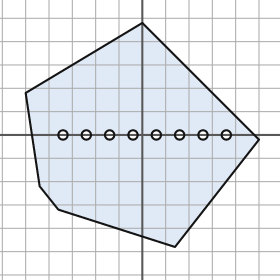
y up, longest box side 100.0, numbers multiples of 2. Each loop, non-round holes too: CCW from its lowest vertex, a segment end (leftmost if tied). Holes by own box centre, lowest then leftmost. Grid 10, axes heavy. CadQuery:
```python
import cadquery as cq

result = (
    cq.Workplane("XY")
    .moveTo(14.0, -48.0)
    .lineTo(50.0, -2.0)
    .lineTo(0.0, 48.0)
    .lineTo(-50.0, 18.0)
    .lineTo(-44.0, -22.0)
    .lineTo(-36.0, -32.0)
    .close()
    .moveTo(-34.0, 0.0)
    .circle(2.0)
    .moveTo(-24.0, 0.0)
    .circle(2.0)
    .moveTo(-14.0, 0.0)
    .circle(2.0)
    .moveTo(-4.0, 0.0)
    .circle(2.0)
    .moveTo(6.0, 0.0)
    .circle(2.0)
    .moveTo(16.0, 0.0)
    .circle(2.0)
    .moveTo(26.0, 0.0)
    .circle(2.0)
    .moveTo(36.0, 0.0)
    .circle(2.0)
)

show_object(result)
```